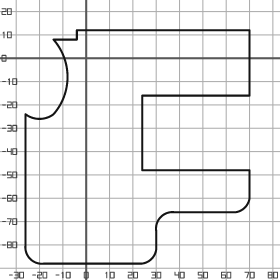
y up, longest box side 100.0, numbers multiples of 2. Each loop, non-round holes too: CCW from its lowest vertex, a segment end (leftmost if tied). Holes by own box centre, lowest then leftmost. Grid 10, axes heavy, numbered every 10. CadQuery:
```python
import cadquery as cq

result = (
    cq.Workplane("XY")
    .moveTo(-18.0, -88.0)
    .lineTo(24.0, -88.0)
    .threePointArc((28.0, -86.0), (30.0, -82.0))
    .lineTo(30.0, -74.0)
    .threePointArc((32.0, -68.0), (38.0, -66.0))
    .lineTo(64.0, -66.0)
    .threePointArc((68.0, -64.0), (70.0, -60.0))
    .lineTo(70.0, -48.0)
    .lineTo(24.0, -48.0)
    .lineTo(24.0, -16.0)
    .lineTo(70.0, -16.0)
    .lineTo(70.0, 12.0)
    .lineTo(-4.0, 12.0)
    .lineTo(-4.0, 8.0)
    .lineTo(-14.0, 8.0)
    .threePointArc((-8.0, -8.0), (-14.0, -24.0))
    .threePointArc((-20.0, -26.0), (-26.0, -24.0))
    .lineTo(-26.0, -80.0)
    .threePointArc((-24.0, -86.0), (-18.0, -88.0))
    .close()
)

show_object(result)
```